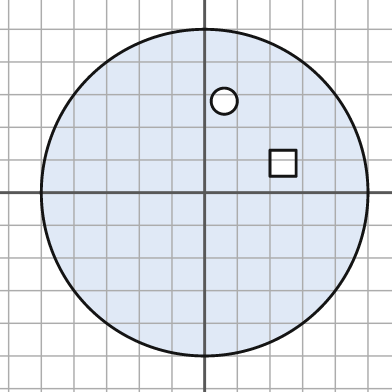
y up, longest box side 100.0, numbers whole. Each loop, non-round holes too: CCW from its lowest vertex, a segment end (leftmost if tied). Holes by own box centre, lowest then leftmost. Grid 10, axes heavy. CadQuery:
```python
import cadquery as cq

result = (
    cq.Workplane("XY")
    .moveTo(0.0, 0.0)
    .circle(50.0)
    .moveTo(20.0, 5.0)
    .lineTo(28.0, 5.0)
    .lineTo(28.0, 13.0)
    .lineTo(20.0, 13.0)
    .close()
    .moveTo(6.0, 28.0)
    .circle(4.0)
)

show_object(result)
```